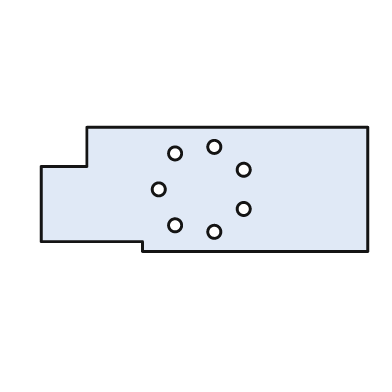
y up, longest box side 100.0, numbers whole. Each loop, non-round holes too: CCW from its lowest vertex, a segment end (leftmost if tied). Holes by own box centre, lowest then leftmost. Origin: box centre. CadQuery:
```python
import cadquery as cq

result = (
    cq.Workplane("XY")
    .moveTo(-19.0, -19.0)
    .lineTo(50.0, -19.0)
    .lineTo(50.0, 19.0)
    .lineTo(-36.0, 19.0)
    .lineTo(-36.0, 7.0)
    .lineTo(-50.0, 7.0)
    .lineTo(-50.0, -16.0)
    .lineTo(-19.0, -16.0)
    .close()
    .moveTo(3.0, -13.0)
    .circle(2.0)
    .moveTo(-9.0, -11.0)
    .circle(2.0)
    .moveTo(12.0, -6.0)
    .circle(2.0)
    .moveTo(-14.0, 0.0)
    .circle(2.0)
    .moveTo(12.0, 6.0)
    .circle(2.0)
    .moveTo(-9.0, 11.0)
    .circle(2.0)
    .moveTo(3.0, 13.0)
    .circle(2.0)
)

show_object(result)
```